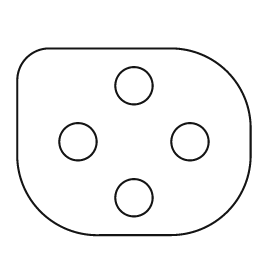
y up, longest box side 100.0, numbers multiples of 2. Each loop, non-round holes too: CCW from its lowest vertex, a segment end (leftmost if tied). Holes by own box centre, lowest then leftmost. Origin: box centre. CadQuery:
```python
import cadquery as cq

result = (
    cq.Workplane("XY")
    .moveTo(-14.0, -40.0)
    .lineTo(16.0, -40.0)
    .threePointArc((40.0, -30.0), (50.0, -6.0))
    .lineTo(50.0, 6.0)
    .threePointArc((40.0, 30.0), (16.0, 40.0))
    .lineTo(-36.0, 40.0)
    .threePointArc((-46.0, 36.0), (-50.0, 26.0))
    .lineTo(-50.0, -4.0)
    .threePointArc((-40.0, -30.0), (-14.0, -40.0))
    .close()
    .moveTo(0.0, -24.0)
    .circle(8.0)
    .moveTo(-24.0, 0.0)
    .circle(8.0)
    .moveTo(24.0, 0.0)
    .circle(8.0)
    .moveTo(0.0, 24.0)
    .circle(8.0)
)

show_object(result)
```